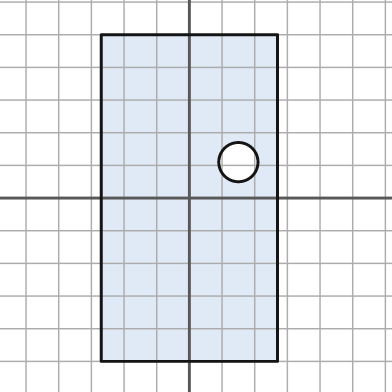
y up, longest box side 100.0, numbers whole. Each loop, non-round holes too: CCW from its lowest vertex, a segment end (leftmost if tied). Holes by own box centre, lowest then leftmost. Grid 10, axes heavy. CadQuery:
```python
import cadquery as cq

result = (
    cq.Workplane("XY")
    .moveTo(-27.0, -50.0)
    .lineTo(27.0, -50.0)
    .lineTo(27.0, 50.0)
    .lineTo(-27.0, 50.0)
    .close()
    .moveTo(15.0, 11.0)
    .circle(6.0)
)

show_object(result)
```